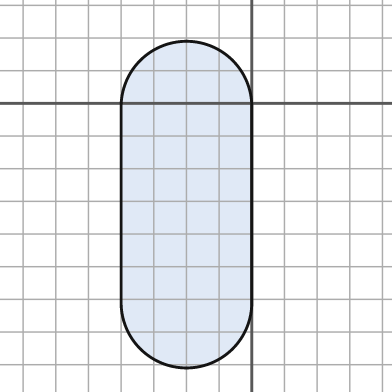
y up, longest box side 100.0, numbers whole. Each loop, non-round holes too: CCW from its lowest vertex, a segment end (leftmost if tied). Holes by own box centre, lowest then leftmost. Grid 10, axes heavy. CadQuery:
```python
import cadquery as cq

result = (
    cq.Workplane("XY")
    .moveTo(-40.0, -61.0)
    .threePointArc((-20.0, -81.0), (0.0, -61.0))
    .lineTo(0.0, -1.0)
    .threePointArc((-20.0, 19.0), (-40.0, -1.0))
    .close()
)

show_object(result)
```